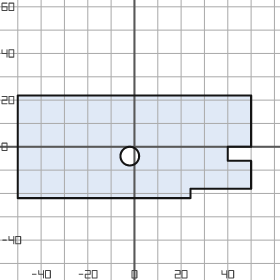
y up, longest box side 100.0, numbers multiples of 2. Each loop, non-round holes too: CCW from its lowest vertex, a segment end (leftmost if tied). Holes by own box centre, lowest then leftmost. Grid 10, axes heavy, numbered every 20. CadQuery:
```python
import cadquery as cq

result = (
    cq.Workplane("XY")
    .moveTo(-50.0, -22.0)
    .lineTo(24.0, -22.0)
    .lineTo(24.0, -18.0)
    .lineTo(50.0, -18.0)
    .lineTo(50.0, -6.0)
    .lineTo(40.0, -6.0)
    .lineTo(40.0, 0.0)
    .lineTo(50.0, 0.0)
    .lineTo(50.0, 22.0)
    .lineTo(-50.0, 22.0)
    .close()
    .moveTo(-2.0, -4.0)
    .circle(4.0)
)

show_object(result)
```